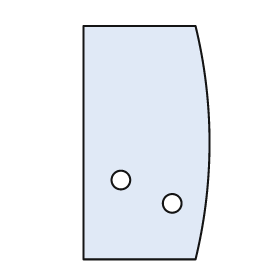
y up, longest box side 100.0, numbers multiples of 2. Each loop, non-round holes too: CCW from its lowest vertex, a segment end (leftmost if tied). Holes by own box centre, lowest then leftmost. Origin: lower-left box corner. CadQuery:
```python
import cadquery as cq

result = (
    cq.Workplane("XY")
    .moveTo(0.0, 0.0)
    .lineTo(48.0, 0.0)
    .threePointArc((54.0, 50.0), (48.0, 100.0))
    .lineTo(0.0, 100.0)
    .close()
    .moveTo(38.0, 24.0)
    .circle(4.0)
    .moveTo(16.0, 34.0)
    .circle(4.0)
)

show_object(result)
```